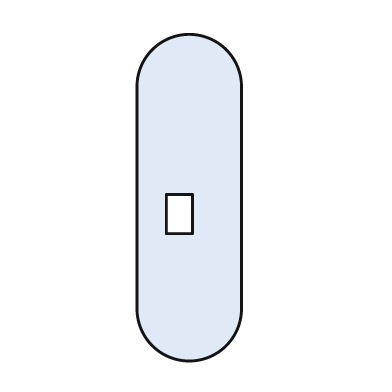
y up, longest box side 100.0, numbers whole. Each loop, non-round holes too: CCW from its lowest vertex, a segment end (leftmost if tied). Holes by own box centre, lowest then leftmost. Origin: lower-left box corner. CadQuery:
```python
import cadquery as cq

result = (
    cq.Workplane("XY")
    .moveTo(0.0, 16.0)
    .threePointArc((16.0, 0.0), (32.0, 16.0))
    .lineTo(32.0, 84.0)
    .threePointArc((16.0, 100.0), (0.0, 84.0))
    .close()
    .moveTo(9.0, 39.0)
    .lineTo(17.0, 39.0)
    .lineTo(17.0, 51.0)
    .lineTo(9.0, 51.0)
    .close()
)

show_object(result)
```